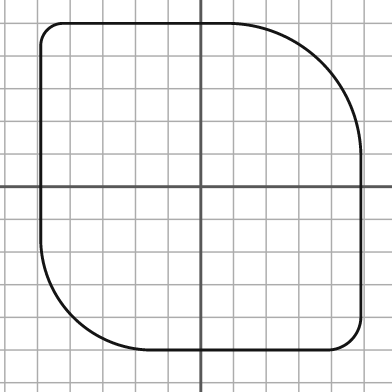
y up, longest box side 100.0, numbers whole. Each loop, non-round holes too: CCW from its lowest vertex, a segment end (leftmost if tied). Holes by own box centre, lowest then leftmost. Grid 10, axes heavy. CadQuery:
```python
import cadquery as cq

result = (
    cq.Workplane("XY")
    .moveTo(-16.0, -50.0)
    .lineTo(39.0, -50.0)
    .threePointArc((46.0, -47.0), (49.0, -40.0))
    .lineTo(49.0, 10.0)
    .threePointArc((37.0, 38.0), (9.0, 50.0))
    .lineTo(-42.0, 50.0)
    .threePointArc((-47.0, 48.0), (-49.0, 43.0))
    .lineTo(-49.0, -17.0)
    .threePointArc((-39.0, -40.0), (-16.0, -50.0))
    .close()
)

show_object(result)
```